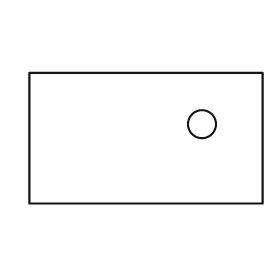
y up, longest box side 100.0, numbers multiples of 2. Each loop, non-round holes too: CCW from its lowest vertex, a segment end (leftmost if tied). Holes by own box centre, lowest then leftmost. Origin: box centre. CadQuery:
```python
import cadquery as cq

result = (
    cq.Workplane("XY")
    .moveTo(-50.0, -28.0)
    .lineTo(50.0, -28.0)
    .lineTo(50.0, 28.0)
    .lineTo(-50.0, 28.0)
    .close()
    .moveTo(24.0, 6.0)
    .circle(6.0)
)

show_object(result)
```